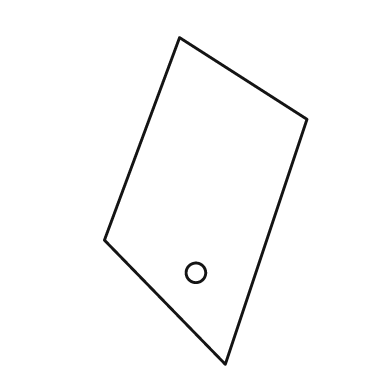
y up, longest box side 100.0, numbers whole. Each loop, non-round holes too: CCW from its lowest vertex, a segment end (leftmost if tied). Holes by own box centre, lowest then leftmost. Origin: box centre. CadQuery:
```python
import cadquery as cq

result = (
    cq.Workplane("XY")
    .moveTo(6.0, -50.0)
    .lineTo(31.0, 25.0)
    .lineTo(-8.0, 50.0)
    .lineTo(-31.0, -12.0)
    .close()
    .moveTo(-3.0, -22.0)
    .circle(3.0)
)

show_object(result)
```